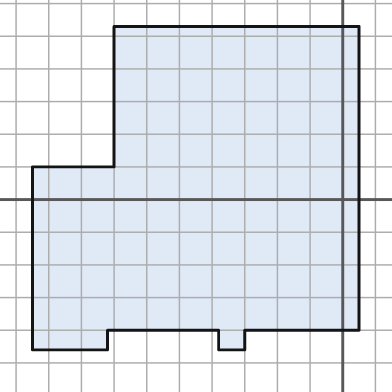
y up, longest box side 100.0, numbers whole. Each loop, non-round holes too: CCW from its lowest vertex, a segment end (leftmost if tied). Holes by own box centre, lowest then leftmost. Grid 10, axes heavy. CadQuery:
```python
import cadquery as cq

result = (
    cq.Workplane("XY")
    .moveTo(-95.0, -46.0)
    .lineTo(-72.0, -46.0)
    .lineTo(-72.0, -40.0)
    .lineTo(-38.0, -40.0)
    .lineTo(-38.0, -46.0)
    .lineTo(-30.0, -46.0)
    .lineTo(-30.0, -40.0)
    .lineTo(5.0, -40.0)
    .lineTo(5.0, 53.0)
    .lineTo(-70.0, 53.0)
    .lineTo(-70.0, 10.0)
    .lineTo(-95.0, 10.0)
    .close()
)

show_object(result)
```